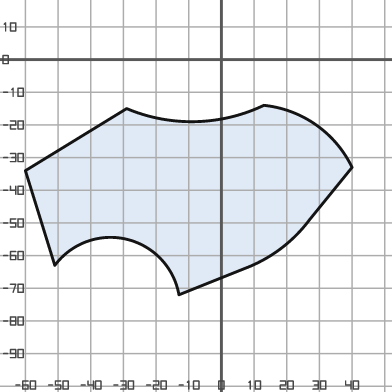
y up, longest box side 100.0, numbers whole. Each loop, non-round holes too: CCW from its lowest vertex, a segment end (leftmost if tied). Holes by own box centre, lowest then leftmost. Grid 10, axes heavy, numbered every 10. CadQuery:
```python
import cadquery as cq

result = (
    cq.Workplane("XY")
    .moveTo(-13.0, -72.0)
    .lineTo(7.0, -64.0)
    .threePointArc((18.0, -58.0), (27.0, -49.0))
    .lineTo(40.0, -33.0)
    .threePointArc((29.0, -20.0), (13.0, -14.0))
    .threePointArc((-8.0, -19.0), (-29.0, -15.0))
    .lineTo(-60.0, -34.0)
    .lineTo(-51.0, -63.0)
    .threePointArc((-29.0, -55.0), (-13.0, -72.0))
    .close()
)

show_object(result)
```